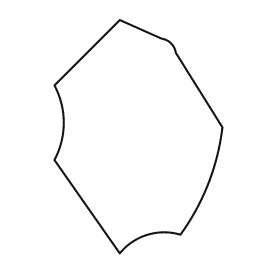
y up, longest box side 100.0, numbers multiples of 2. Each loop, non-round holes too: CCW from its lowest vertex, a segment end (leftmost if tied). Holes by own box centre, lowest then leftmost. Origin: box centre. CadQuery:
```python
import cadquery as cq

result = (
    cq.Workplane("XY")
    .moveTo(-8.0, -50.0)
    .threePointArc((4.0, -42.0), (18.0, -42.0))
    .threePointArc((30.0, -20.0), (36.0, 4.0))
    .lineTo(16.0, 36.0)
    .threePointArc((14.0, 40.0), (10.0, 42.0))
    .lineTo(-8.0, 50.0)
    .lineTo(-36.0, 22.0)
    .threePointArc((-32.0, 6.0), (-36.0, -10.0))
    .close()
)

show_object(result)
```